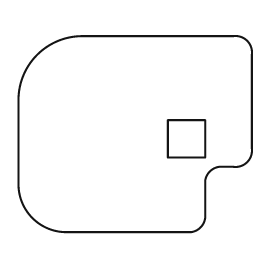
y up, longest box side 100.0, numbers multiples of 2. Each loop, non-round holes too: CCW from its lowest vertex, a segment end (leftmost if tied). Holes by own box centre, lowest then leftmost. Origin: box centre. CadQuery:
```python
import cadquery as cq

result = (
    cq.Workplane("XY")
    .moveTo(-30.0, -42.0)
    .lineTo(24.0, -42.0)
    .threePointArc((28.0, -40.0), (30.0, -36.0))
    .lineTo(30.0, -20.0)
    .threePointArc((32.0, -16.0), (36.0, -14.0))
    .lineTo(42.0, -14.0)
    .threePointArc((48.0, -12.0), (50.0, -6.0))
    .lineTo(50.0, 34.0)
    .threePointArc((48.0, 40.0), (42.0, 42.0))
    .lineTo(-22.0, 42.0)
    .threePointArc((-42.0, 34.0), (-50.0, 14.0))
    .lineTo(-50.0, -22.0)
    .threePointArc((-44.0, -36.0), (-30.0, -42.0))
    .close()
    .moveTo(14.0, -10.0)
    .lineTo(30.0, -10.0)
    .lineTo(30.0, 6.0)
    .lineTo(14.0, 6.0)
    .close()
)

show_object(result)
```